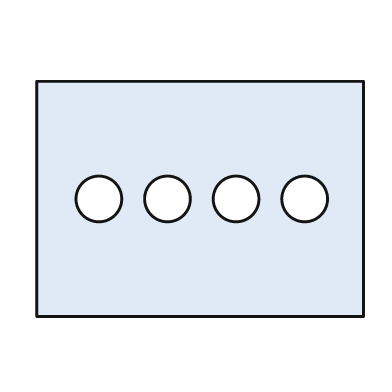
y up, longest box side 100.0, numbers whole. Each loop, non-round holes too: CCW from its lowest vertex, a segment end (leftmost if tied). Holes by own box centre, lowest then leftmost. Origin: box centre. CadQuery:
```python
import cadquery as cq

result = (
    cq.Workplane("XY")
    .moveTo(-50.0, -36.0)
    .lineTo(50.0, -36.0)
    .lineTo(50.0, 36.0)
    .lineTo(-50.0, 36.0)
    .close()
    .moveTo(-31.0, 0.0)
    .circle(7.0)
    .moveTo(-10.0, 0.0)
    .circle(7.0)
    .moveTo(11.0, 0.0)
    .circle(7.0)
    .moveTo(32.0, 0.0)
    .circle(7.0)
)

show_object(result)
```